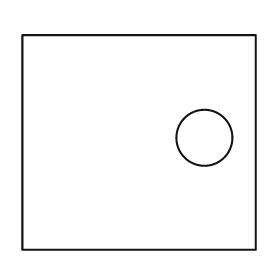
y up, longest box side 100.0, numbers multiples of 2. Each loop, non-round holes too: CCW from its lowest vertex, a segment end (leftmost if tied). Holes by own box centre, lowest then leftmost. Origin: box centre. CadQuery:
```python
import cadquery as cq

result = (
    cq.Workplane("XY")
    .moveTo(-50.0, -46.0)
    .lineTo(50.0, -46.0)
    .lineTo(50.0, 46.0)
    .lineTo(-50.0, 46.0)
    .close()
    .moveTo(28.0, 2.0)
    .circle(12.0)
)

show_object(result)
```